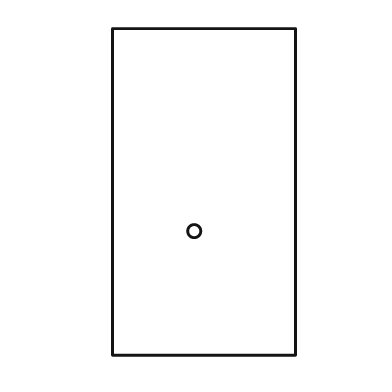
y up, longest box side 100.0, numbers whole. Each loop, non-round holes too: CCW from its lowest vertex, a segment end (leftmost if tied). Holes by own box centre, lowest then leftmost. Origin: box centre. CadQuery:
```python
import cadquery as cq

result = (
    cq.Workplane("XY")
    .moveTo(-28.0, -50.0)
    .lineTo(28.0, -50.0)
    .lineTo(28.0, 50.0)
    .lineTo(-28.0, 50.0)
    .close()
    .moveTo(-3.0, -12.0)
    .circle(2.0)
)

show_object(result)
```